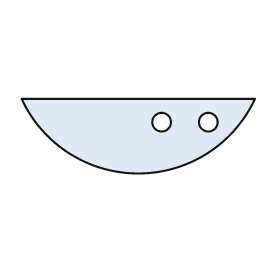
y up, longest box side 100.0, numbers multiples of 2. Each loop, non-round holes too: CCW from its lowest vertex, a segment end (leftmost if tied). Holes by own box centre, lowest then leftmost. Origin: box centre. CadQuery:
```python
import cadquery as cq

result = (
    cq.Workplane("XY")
    .moveTo(-50.0, 16.0)
    .threePointArc((0.0, -16.0), (50.0, 16.0))
    .close()
    .moveTo(10.0, 6.0)
    .circle(4.0)
    .moveTo(30.0, 6.0)
    .circle(4.0)
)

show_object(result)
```